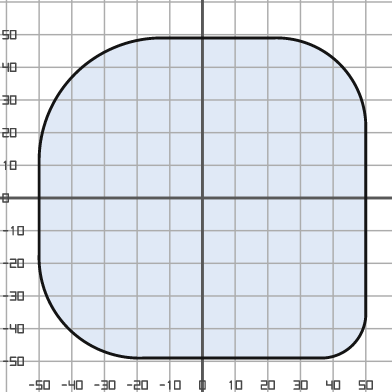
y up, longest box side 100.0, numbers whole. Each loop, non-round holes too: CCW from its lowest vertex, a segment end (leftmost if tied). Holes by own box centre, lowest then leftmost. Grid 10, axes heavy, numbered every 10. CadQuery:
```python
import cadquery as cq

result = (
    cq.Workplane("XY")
    .moveTo(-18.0, -49.0)
    .lineTo(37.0, -49.0)
    .threePointArc((46.0, -45.0), (50.0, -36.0))
    .lineTo(50.0, 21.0)
    .threePointArc((42.0, 41.0), (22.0, 49.0))
    .lineTo(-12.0, 49.0)
    .threePointArc((-39.0, 38.0), (-50.0, 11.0))
    .lineTo(-50.0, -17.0)
    .threePointArc((-41.0, -40.0), (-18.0, -49.0))
    .close()
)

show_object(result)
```